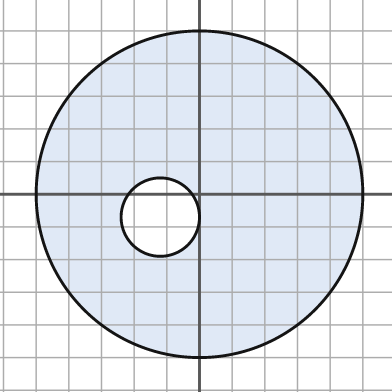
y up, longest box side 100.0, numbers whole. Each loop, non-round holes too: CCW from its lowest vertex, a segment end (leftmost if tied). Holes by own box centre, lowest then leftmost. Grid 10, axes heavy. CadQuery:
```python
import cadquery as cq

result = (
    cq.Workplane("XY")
    .moveTo(0.0, 0.0)
    .circle(50.0)
    .moveTo(-12.0, -7.0)
    .circle(12.0)
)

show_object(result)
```